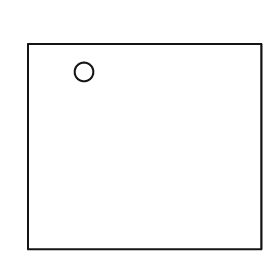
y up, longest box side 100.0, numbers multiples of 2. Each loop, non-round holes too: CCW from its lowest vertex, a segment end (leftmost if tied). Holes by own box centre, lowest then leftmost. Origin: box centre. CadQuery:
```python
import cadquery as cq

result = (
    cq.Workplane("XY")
    .moveTo(-50.0, -44.0)
    .lineTo(50.0, -44.0)
    .lineTo(50.0, 44.0)
    .lineTo(-50.0, 44.0)
    .close()
    .moveTo(-26.0, 32.0)
    .circle(4.0)
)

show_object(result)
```